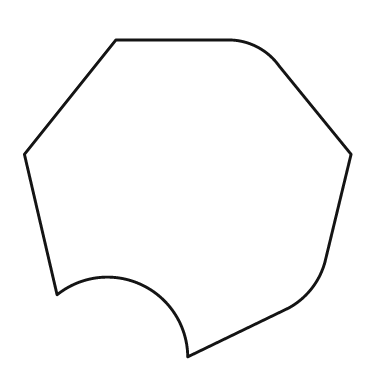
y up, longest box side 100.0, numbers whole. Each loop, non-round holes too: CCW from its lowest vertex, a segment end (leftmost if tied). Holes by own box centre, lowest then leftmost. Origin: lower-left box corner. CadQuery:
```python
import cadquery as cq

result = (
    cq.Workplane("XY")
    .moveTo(50.0, 0.0)
    .lineTo(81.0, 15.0)
    .threePointArc((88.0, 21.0), (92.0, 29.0))
    .lineTo(100.0, 62.0)
    .lineTo(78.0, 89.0)
    .threePointArc((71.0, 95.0), (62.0, 97.0))
    .lineTo(28.0, 97.0)
    .lineTo(0.0, 62.0)
    .lineTo(10.0, 19.0)
    .threePointArc((36.0, 22.0), (50.0, 0.0))
    .close()
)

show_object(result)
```